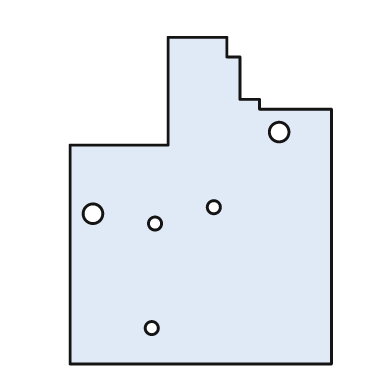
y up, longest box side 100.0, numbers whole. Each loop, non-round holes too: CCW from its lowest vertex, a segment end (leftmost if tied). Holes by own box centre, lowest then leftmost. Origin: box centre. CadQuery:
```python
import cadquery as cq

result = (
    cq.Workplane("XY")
    .moveTo(-40.0, -50.0)
    .lineTo(40.0, -50.0)
    .lineTo(40.0, 28.0)
    .lineTo(18.0, 28.0)
    .lineTo(18.0, 31.0)
    .lineTo(12.0, 31.0)
    .lineTo(12.0, 44.0)
    .lineTo(8.0, 44.0)
    .lineTo(8.0, 50.0)
    .lineTo(-10.0, 50.0)
    .lineTo(-10.0, 17.0)
    .lineTo(-40.0, 17.0)
    .close()
    .moveTo(-15.0, -39.0)
    .circle(2.0)
    .moveTo(-14.0, -7.0)
    .circle(2.0)
    .moveTo(-33.0, -4.0)
    .circle(3.0)
    .moveTo(4.0, -2.0)
    .circle(2.0)
    .moveTo(24.0, 21.0)
    .circle(3.0)
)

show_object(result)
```